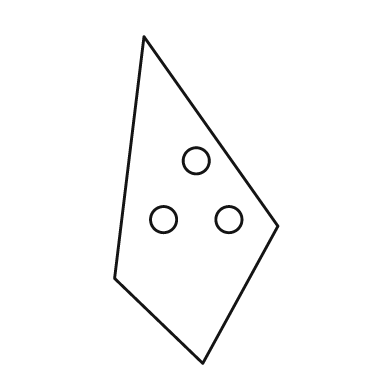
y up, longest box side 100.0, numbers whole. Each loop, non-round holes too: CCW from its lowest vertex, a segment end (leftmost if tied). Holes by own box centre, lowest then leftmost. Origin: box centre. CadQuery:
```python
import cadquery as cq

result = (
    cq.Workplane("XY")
    .moveTo(2.0, -50.0)
    .lineTo(25.0, -8.0)
    .lineTo(-16.0, 50.0)
    .lineTo(-25.0, -24.0)
    .close()
    .moveTo(-10.0, -6.0)
    .circle(4.0)
    .moveTo(10.0, -6.0)
    .circle(4.0)
    .moveTo(0.0, 12.0)
    .circle(4.0)
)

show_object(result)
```